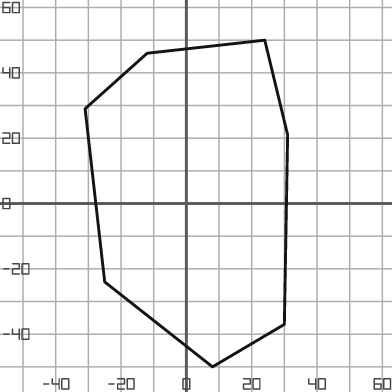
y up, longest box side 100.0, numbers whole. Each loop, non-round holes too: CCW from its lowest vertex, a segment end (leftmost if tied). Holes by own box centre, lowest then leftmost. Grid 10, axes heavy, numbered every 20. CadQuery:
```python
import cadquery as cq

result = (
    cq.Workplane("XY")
    .moveTo(8.0, -50.0)
    .lineTo(30.0, -37.0)
    .lineTo(31.0, 21.0)
    .lineTo(24.0, 50.0)
    .lineTo(-12.0, 46.0)
    .lineTo(-31.0, 29.0)
    .lineTo(-25.0, -24.0)
    .close()
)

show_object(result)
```